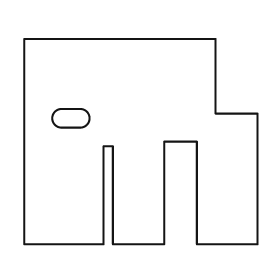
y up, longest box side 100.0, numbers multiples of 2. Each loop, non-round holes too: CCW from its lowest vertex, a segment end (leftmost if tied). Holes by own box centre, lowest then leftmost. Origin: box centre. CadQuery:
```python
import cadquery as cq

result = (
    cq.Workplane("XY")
    .moveTo(-50.0, -44.0)
    .lineTo(-16.0, -44.0)
    .lineTo(-16.0, -2.0)
    .lineTo(-12.0, -2.0)
    .lineTo(-12.0, -44.0)
    .lineTo(10.0, -44.0)
    .lineTo(10.0, 0.0)
    .lineTo(24.0, 0.0)
    .lineTo(24.0, -44.0)
    .lineTo(50.0, -44.0)
    .lineTo(50.0, 12.0)
    .lineTo(32.0, 12.0)
    .lineTo(32.0, 44.0)
    .lineTo(-50.0, 44.0)
    .close()
    .moveTo(-34.0, 6.0)
    .lineTo(-26.0, 6.0)
    .threePointArc((-22.0, 10.0), (-26.0, 14.0))
    .lineTo(-34.0, 14.0)
    .threePointArc((-38.0, 10.0), (-34.0, 6.0))
    .close()
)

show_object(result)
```